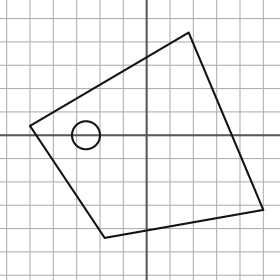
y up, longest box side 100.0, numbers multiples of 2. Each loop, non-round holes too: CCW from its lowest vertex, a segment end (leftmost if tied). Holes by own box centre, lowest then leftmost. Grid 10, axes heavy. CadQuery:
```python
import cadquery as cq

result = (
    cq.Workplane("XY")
    .moveTo(-18.0, -44.0)
    .lineTo(50.0, -32.0)
    .lineTo(18.0, 44.0)
    .lineTo(-50.0, 4.0)
    .close()
    .moveTo(-26.0, 0.0)
    .circle(6.0)
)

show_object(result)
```